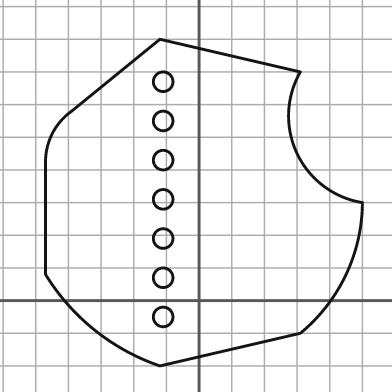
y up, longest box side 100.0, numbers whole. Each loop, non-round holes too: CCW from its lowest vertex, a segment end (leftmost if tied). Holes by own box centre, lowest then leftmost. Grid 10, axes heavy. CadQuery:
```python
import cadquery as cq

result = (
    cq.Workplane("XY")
    .moveTo(-12.0, -20.0)
    .lineTo(31.0, -10.0)
    .threePointArc((45.0, 8.0), (50.0, 30.0))
    .threePointArc((30.0, 45.0), (31.0, 70.0))
    .lineTo(-12.0, 80.0)
    .lineTo(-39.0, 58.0)
    .threePointArc((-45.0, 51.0), (-47.0, 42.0))
    .lineTo(-47.0, 8.0)
    .threePointArc((-32.0, -9.0), (-12.0, -20.0))
    .close()
    .moveTo(-11.0, -5.0)
    .circle(3.0)
    .moveTo(-11.0, 7.0)
    .circle(3.0)
    .moveTo(-11.0, 19.0)
    .circle(3.0)
    .moveTo(-11.0, 31.0)
    .circle(3.0)
    .moveTo(-11.0, 43.0)
    .circle(3.0)
    .moveTo(-11.0, 55.0)
    .circle(3.0)
    .moveTo(-11.0, 67.0)
    .circle(3.0)
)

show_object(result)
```